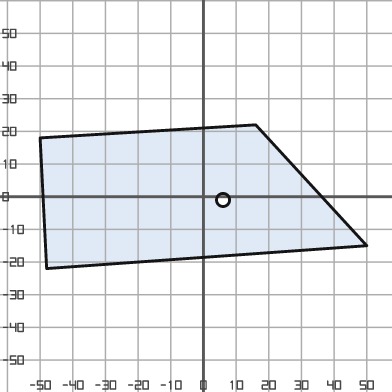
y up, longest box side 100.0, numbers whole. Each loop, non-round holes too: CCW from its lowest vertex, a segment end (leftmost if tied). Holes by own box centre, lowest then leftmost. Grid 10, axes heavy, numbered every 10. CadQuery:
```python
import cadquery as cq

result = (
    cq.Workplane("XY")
    .moveTo(-48.0, -22.0)
    .lineTo(50.0, -15.0)
    .lineTo(16.0, 22.0)
    .lineTo(-50.0, 18.0)
    .close()
    .moveTo(6.0, -1.0)
    .circle(2.0)
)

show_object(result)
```